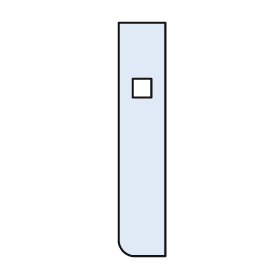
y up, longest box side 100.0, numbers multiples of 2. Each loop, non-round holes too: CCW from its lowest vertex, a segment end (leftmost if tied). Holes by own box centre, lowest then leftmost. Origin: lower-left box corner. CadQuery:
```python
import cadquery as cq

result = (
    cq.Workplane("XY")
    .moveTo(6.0, 0.0)
    .lineTo(20.0, 0.0)
    .lineTo(20.0, 100.0)
    .lineTo(0.0, 100.0)
    .lineTo(0.0, 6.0)
    .threePointArc((2.0, 2.0), (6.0, 0.0))
    .close()
    .moveTo(6.0, 68.0)
    .lineTo(14.0, 68.0)
    .lineTo(14.0, 76.0)
    .lineTo(6.0, 76.0)
    .close()
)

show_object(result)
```